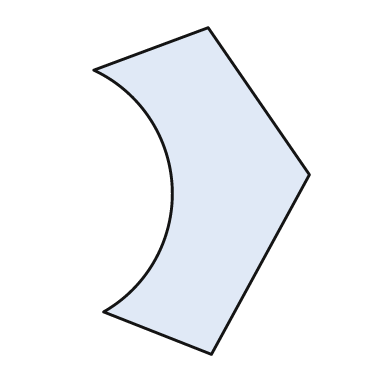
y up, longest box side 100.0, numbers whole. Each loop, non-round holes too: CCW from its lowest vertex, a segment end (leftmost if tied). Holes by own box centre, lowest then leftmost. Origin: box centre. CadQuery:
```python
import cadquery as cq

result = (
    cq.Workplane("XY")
    .moveTo(3.0, -50.0)
    .lineTo(33.0, 5.0)
    .lineTo(2.0, 50.0)
    .lineTo(-33.0, 37.0)
    .threePointArc((-9.0, 1.0), (-30.0, -37.0))
    .close()
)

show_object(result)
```